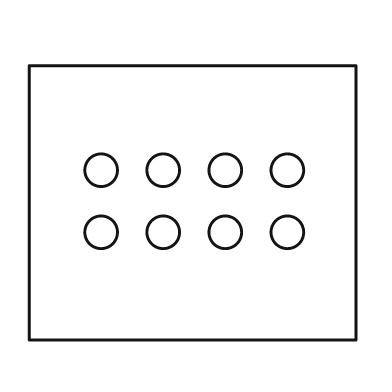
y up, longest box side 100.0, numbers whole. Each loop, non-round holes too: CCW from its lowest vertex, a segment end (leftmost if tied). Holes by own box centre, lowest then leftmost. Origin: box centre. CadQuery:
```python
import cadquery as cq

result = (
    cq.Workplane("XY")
    .moveTo(-50.0, -42.0)
    .lineTo(50.0, -42.0)
    .lineTo(50.0, 42.0)
    .lineTo(-50.0, 42.0)
    .close()
    .moveTo(-28.0, -9.0)
    .circle(5.0)
    .moveTo(-9.0, -9.0)
    .circle(5.0)
    .moveTo(10.0, -9.0)
    .circle(5.0)
    .moveTo(29.0, -9.0)
    .circle(5.0)
    .moveTo(-28.0, 10.0)
    .circle(5.0)
    .moveTo(-9.0, 10.0)
    .circle(5.0)
    .moveTo(10.0, 10.0)
    .circle(5.0)
    .moveTo(29.0, 10.0)
    .circle(5.0)
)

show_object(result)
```